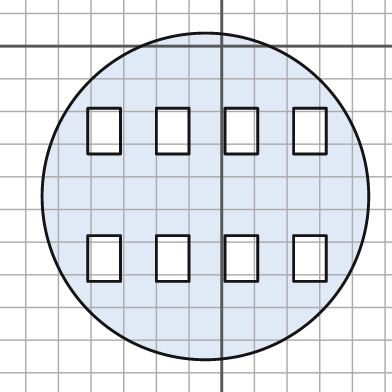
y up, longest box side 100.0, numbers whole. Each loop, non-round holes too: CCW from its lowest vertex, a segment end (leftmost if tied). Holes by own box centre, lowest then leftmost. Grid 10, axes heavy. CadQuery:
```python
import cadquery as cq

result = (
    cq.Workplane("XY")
    .moveTo(-5.0, -46.0)
    .circle(50.0)
    .moveTo(-41.0, -72.0)
    .lineTo(-31.0, -72.0)
    .lineTo(-31.0, -58.0)
    .lineTo(-41.0, -58.0)
    .close()
    .moveTo(-20.0, -72.0)
    .lineTo(-10.0, -72.0)
    .lineTo(-10.0, -58.0)
    .lineTo(-20.0, -58.0)
    .close()
    .moveTo(1.0, -72.0)
    .lineTo(11.0, -72.0)
    .lineTo(11.0, -58.0)
    .lineTo(1.0, -58.0)
    .close()
    .moveTo(22.0, -72.0)
    .lineTo(32.0, -72.0)
    .lineTo(32.0, -58.0)
    .lineTo(22.0, -58.0)
    .close()
    .moveTo(-41.0, -33.0)
    .lineTo(-31.0, -33.0)
    .lineTo(-31.0, -19.0)
    .lineTo(-41.0, -19.0)
    .close()
    .moveTo(-20.0, -33.0)
    .lineTo(-10.0, -33.0)
    .lineTo(-10.0, -19.0)
    .lineTo(-20.0, -19.0)
    .close()
    .moveTo(1.0, -33.0)
    .lineTo(11.0, -33.0)
    .lineTo(11.0, -19.0)
    .lineTo(1.0, -19.0)
    .close()
    .moveTo(22.0, -33.0)
    .lineTo(32.0, -33.0)
    .lineTo(32.0, -19.0)
    .lineTo(22.0, -19.0)
    .close()
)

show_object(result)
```